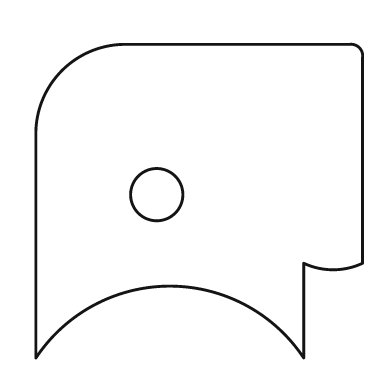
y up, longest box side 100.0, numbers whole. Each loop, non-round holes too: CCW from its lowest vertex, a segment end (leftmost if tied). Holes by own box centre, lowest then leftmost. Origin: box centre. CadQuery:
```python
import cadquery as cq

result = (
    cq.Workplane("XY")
    .moveTo(-50.0, -48.0)
    .threePointArc((-9.0, -26.0), (32.0, -48.0))
    .lineTo(32.0, -19.0)
    .threePointArc((41.0, -21.0), (50.0, -19.0))
    .lineTo(50.0, 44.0)
    .threePointArc((49.0, 47.0), (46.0, 48.0))
    .lineTo(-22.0, 48.0)
    .threePointArc((-42.0, 40.0), (-50.0, 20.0))
    .close()
    .moveTo(-13.0, 2.0)
    .circle(8.0)
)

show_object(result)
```